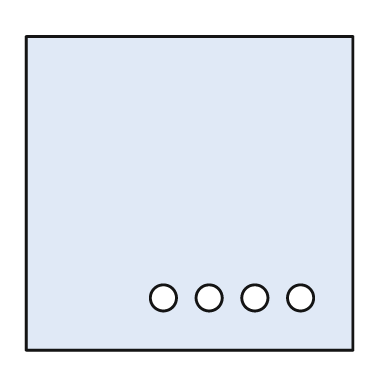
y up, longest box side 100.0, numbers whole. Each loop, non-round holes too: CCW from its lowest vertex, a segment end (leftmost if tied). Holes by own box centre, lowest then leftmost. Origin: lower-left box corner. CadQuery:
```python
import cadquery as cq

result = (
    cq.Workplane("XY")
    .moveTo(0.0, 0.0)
    .lineTo(100.0, 0.0)
    .lineTo(100.0, 96.0)
    .lineTo(0.0, 96.0)
    .close()
    .moveTo(42.0, 16.0)
    .circle(4.0)
    .moveTo(56.0, 16.0)
    .circle(4.0)
    .moveTo(70.0, 16.0)
    .circle(4.0)
    .moveTo(84.0, 16.0)
    .circle(4.0)
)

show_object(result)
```